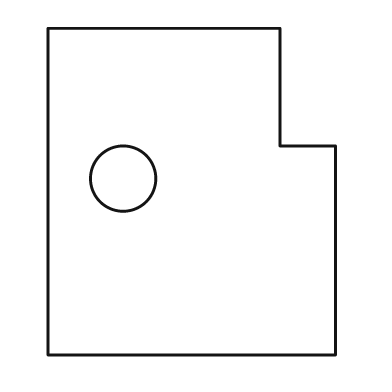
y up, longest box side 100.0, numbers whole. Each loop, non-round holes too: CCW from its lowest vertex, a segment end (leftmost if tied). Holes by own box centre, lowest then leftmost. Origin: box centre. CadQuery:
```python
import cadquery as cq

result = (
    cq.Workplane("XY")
    .moveTo(-44.0, -50.0)
    .lineTo(44.0, -50.0)
    .lineTo(44.0, 14.0)
    .lineTo(27.0, 14.0)
    .lineTo(27.0, 50.0)
    .lineTo(-44.0, 50.0)
    .close()
    .moveTo(-21.0, 4.0)
    .circle(10.0)
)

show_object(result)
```